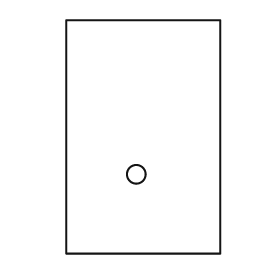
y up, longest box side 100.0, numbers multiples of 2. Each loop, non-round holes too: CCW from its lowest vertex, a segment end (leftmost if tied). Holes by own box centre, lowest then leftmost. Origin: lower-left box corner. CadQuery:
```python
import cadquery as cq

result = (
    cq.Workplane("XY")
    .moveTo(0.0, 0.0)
    .lineTo(66.0, 0.0)
    .lineTo(66.0, 100.0)
    .lineTo(0.0, 100.0)
    .close()
    .moveTo(30.0, 34.0)
    .circle(4.0)
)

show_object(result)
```